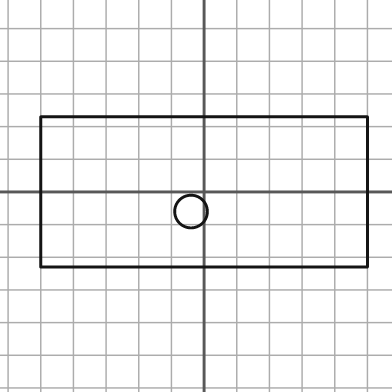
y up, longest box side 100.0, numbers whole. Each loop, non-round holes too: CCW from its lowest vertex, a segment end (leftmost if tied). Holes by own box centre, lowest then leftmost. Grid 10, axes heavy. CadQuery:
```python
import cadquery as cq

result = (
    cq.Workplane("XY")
    .moveTo(-50.0, -23.0)
    .lineTo(50.0, -23.0)
    .lineTo(50.0, 23.0)
    .lineTo(-50.0, 23.0)
    .close()
    .moveTo(-4.0, -6.0)
    .circle(5.0)
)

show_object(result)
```